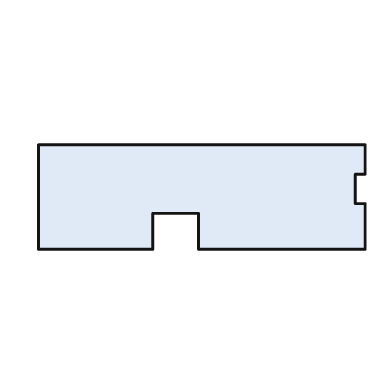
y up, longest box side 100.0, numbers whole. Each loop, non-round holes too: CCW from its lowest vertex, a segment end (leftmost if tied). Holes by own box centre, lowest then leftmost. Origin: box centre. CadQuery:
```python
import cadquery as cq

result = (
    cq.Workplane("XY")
    .moveTo(-50.0, -16.0)
    .lineTo(-15.0, -16.0)
    .lineTo(-15.0, -5.0)
    .lineTo(-1.0, -5.0)
    .lineTo(-1.0, -16.0)
    .lineTo(50.0, -16.0)
    .lineTo(50.0, -2.0)
    .lineTo(47.0, -2.0)
    .lineTo(47.0, 7.0)
    .lineTo(50.0, 7.0)
    .lineTo(50.0, 16.0)
    .lineTo(-50.0, 16.0)
    .close()
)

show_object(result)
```